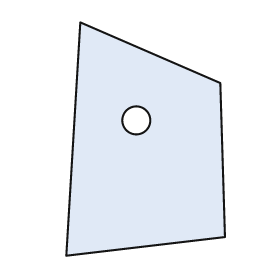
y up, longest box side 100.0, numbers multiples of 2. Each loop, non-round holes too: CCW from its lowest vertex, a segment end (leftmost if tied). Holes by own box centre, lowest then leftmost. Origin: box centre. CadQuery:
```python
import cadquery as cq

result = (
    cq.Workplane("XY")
    .moveTo(-34.0, -50.0)
    .lineTo(34.0, -42.0)
    .lineTo(32.0, 24.0)
    .lineTo(-28.0, 50.0)
    .close()
    .moveTo(-4.0, 8.0)
    .circle(6.0)
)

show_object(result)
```